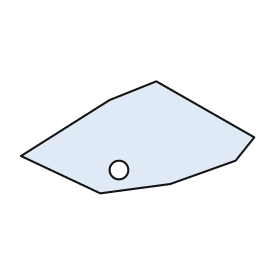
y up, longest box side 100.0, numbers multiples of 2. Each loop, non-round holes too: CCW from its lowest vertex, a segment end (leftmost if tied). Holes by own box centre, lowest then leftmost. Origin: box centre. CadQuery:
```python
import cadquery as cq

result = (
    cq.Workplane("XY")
    .moveTo(-16.0, -24.0)
    .lineTo(14.0, -20.0)
    .lineTo(42.0, -10.0)
    .lineTo(50.0, 0.0)
    .lineTo(8.0, 24.0)
    .lineTo(-12.0, 16.0)
    .lineTo(-50.0, -8.0)
    .close()
    .moveTo(-8.0, -14.0)
    .circle(4.0)
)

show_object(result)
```